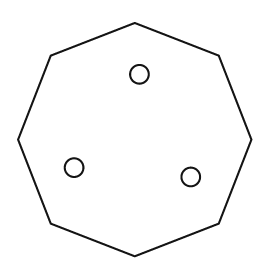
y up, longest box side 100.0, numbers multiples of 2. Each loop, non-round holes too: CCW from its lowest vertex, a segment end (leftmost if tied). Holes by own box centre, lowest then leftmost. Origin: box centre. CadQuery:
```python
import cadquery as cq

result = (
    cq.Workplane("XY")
    .moveTo(0.0, -50.0)
    .lineTo(36.0, -36.0)
    .lineTo(50.0, 0.0)
    .lineTo(36.0, 36.0)
    .lineTo(0.0, 50.0)
    .lineTo(-36.0, 36.0)
    .lineTo(-50.0, 0.0)
    .lineTo(-36.0, -36.0)
    .close()
    .moveTo(24.0, -16.0)
    .circle(4.0)
    .moveTo(-26.0, -12.0)
    .circle(4.0)
    .moveTo(2.0, 28.0)
    .circle(4.0)
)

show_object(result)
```